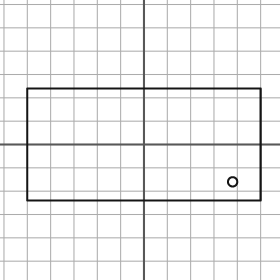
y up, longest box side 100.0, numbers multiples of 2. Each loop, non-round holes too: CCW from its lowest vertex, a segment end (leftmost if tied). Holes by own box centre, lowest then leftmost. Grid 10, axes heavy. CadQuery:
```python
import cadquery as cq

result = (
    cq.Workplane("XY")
    .moveTo(-50.0, -24.0)
    .lineTo(50.0, -24.0)
    .lineTo(50.0, 24.0)
    .lineTo(-50.0, 24.0)
    .close()
    .moveTo(38.0, -16.0)
    .circle(2.0)
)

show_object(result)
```